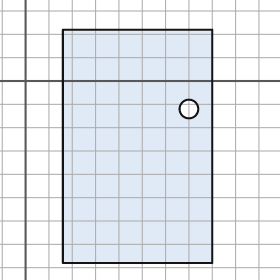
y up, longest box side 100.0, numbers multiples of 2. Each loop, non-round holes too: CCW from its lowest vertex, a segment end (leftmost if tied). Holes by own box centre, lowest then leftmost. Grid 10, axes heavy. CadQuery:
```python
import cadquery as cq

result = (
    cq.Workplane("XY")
    .moveTo(16.0, -78.0)
    .lineTo(80.0, -78.0)
    .lineTo(80.0, 22.0)
    .lineTo(16.0, 22.0)
    .close()
    .moveTo(70.0, -12.0)
    .circle(4.0)
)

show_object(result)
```